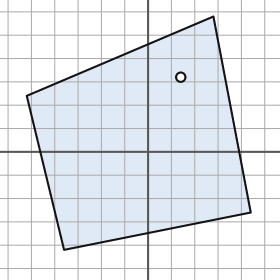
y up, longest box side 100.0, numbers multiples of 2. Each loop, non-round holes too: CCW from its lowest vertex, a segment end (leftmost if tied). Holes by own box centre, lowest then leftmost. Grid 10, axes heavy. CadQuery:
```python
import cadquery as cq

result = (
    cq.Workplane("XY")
    .moveTo(-36.0, -42.0)
    .lineTo(44.0, -26.0)
    .lineTo(28.0, 58.0)
    .lineTo(-52.0, 24.0)
    .close()
    .moveTo(14.0, 32.0)
    .circle(2.0)
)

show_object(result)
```